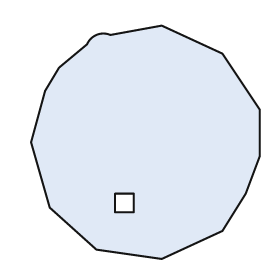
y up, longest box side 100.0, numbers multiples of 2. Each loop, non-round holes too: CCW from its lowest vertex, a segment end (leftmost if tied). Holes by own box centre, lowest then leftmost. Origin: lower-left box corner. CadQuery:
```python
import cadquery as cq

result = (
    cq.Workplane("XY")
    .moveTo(56.0, 0.0)
    .lineTo(82.0, 12.0)
    .lineTo(92.0, 28.0)
    .lineTo(98.0, 44.0)
    .lineTo(98.0, 64.0)
    .lineTo(82.0, 88.0)
    .lineTo(56.0, 100.0)
    .lineTo(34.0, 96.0)
    .threePointArc((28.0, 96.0), (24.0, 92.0))
    .lineTo(12.0, 82.0)
    .lineTo(6.0, 72.0)
    .lineTo(0.0, 50.0)
    .lineTo(8.0, 22.0)
    .lineTo(28.0, 4.0)
    .close()
    .moveTo(36.0, 20.0)
    .lineTo(44.0, 20.0)
    .lineTo(44.0, 28.0)
    .lineTo(36.0, 28.0)
    .close()
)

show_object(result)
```